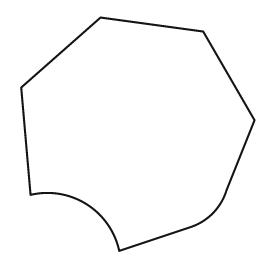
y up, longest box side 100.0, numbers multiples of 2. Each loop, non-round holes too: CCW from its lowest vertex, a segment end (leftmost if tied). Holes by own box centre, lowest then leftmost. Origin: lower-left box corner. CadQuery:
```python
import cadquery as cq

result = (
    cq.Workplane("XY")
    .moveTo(42.0, 0.0)
    .lineTo(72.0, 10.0)
    .threePointArc((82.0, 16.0), (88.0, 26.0))
    .lineTo(100.0, 56.0)
    .lineTo(78.0, 94.0)
    .lineTo(34.0, 100.0)
    .lineTo(0.0, 70.0)
    .lineTo(4.0, 24.0)
    .threePointArc((28.0, 20.0), (42.0, 0.0))
    .close()
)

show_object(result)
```